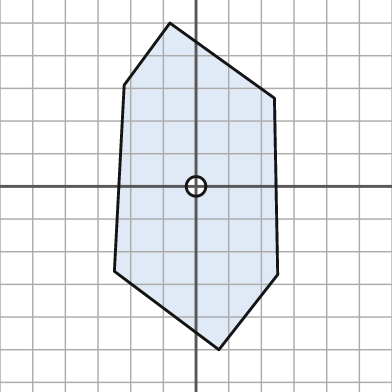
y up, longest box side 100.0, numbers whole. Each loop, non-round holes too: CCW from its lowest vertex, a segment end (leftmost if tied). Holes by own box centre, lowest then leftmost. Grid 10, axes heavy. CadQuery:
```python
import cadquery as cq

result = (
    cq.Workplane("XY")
    .moveTo(7.0, -50.0)
    .lineTo(25.0, -27.0)
    .lineTo(24.0, 27.0)
    .lineTo(-8.0, 50.0)
    .lineTo(-22.0, 31.0)
    .lineTo(-25.0, -26.0)
    .close()
    .moveTo(0.0, 0.0)
    .circle(3.0)
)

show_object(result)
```